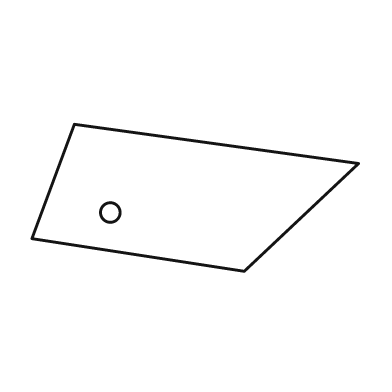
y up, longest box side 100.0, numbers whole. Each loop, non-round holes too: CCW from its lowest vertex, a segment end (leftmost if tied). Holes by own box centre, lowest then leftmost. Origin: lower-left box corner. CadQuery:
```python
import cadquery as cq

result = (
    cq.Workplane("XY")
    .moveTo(65.0, 0.0)
    .lineTo(100.0, 33.0)
    .lineTo(13.0, 45.0)
    .lineTo(0.0, 10.0)
    .close()
    .moveTo(24.0, 18.0)
    .circle(3.0)
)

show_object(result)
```